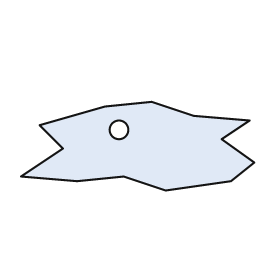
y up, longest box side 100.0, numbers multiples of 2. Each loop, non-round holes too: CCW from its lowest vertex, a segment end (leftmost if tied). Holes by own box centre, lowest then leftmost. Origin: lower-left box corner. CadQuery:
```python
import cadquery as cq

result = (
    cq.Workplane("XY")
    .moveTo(62.0, 0.0)
    .lineTo(90.0, 4.0)
    .lineTo(100.0, 12.0)
    .lineTo(86.0, 22.0)
    .lineTo(98.0, 30.0)
    .lineTo(74.0, 32.0)
    .lineTo(56.0, 38.0)
    .lineTo(36.0, 36.0)
    .lineTo(8.0, 28.0)
    .lineTo(18.0, 18.0)
    .lineTo(0.0, 6.0)
    .lineTo(24.0, 4.0)
    .lineTo(44.0, 6.0)
    .close()
    .moveTo(42.0, 26.0)
    .circle(4.0)
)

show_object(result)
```